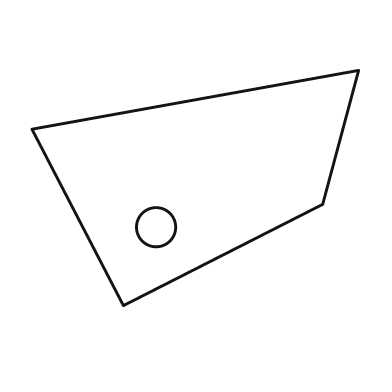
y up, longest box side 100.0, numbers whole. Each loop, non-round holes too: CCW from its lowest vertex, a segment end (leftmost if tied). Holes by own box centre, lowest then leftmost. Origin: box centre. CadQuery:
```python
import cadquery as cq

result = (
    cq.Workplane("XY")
    .moveTo(-22.0, -36.0)
    .lineTo(39.0, -5.0)
    .lineTo(50.0, 36.0)
    .lineTo(-50.0, 18.0)
    .close()
    .moveTo(-12.0, -12.0)
    .circle(6.0)
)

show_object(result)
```